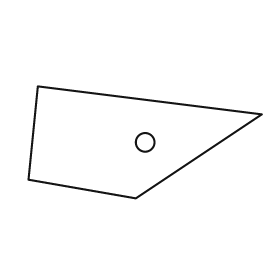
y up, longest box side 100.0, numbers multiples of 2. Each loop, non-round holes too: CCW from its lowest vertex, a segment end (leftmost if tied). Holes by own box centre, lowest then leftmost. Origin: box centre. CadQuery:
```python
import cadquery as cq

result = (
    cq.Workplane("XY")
    .moveTo(-4.0, -24.0)
    .lineTo(50.0, 12.0)
    .lineTo(-46.0, 24.0)
    .lineTo(-50.0, -16.0)
    .close()
    .moveTo(0.0, 0.0)
    .circle(4.0)
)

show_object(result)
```